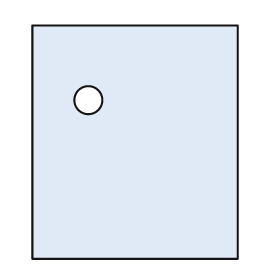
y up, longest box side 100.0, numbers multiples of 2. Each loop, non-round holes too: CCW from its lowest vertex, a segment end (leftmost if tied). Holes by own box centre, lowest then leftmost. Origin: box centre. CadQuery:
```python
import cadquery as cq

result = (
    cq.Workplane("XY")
    .moveTo(-44.0, -50.0)
    .lineTo(44.0, -50.0)
    .lineTo(44.0, 50.0)
    .lineTo(-44.0, 50.0)
    .close()
    .moveTo(-20.0, 18.0)
    .circle(6.0)
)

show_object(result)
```